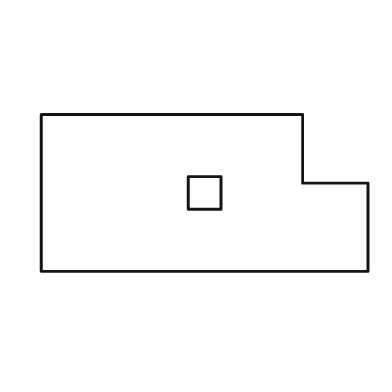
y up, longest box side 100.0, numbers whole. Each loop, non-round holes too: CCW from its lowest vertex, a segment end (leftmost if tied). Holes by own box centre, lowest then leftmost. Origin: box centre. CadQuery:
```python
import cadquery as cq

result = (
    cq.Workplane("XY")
    .moveTo(-50.0, -24.0)
    .lineTo(50.0, -24.0)
    .lineTo(50.0, 3.0)
    .lineTo(30.0, 3.0)
    .lineTo(30.0, 24.0)
    .lineTo(-50.0, 24.0)
    .close()
    .moveTo(-5.0, -5.0)
    .lineTo(5.0, -5.0)
    .lineTo(5.0, 5.0)
    .lineTo(-5.0, 5.0)
    .close()
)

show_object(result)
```